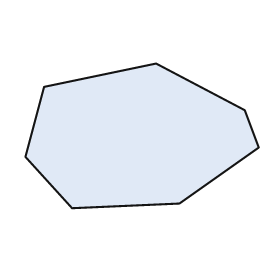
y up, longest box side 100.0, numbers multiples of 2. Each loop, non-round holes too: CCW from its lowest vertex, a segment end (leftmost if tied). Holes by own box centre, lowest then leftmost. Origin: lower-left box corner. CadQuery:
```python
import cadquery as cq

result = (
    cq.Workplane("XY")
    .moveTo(20.0, 0.0)
    .lineTo(66.0, 2.0)
    .lineTo(100.0, 26.0)
    .lineTo(94.0, 42.0)
    .lineTo(56.0, 62.0)
    .lineTo(8.0, 52.0)
    .lineTo(0.0, 22.0)
    .close()
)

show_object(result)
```